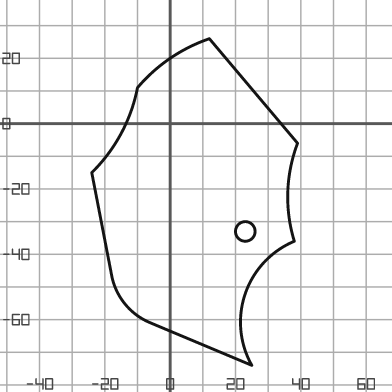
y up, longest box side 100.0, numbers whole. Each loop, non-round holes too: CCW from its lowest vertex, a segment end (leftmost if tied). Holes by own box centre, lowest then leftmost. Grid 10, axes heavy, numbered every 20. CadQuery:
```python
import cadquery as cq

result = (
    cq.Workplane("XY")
    .moveTo(25.0, -74.0)
    .threePointArc((23.0, -52.0), (38.0, -36.0))
    .threePointArc((36.0, -21.0), (39.0, -6.0))
    .lineTo(12.0, 26.0)
    .threePointArc((0.0, 20.0), (-10.0, 11.0))
    .threePointArc((-15.0, -3.0), (-24.0, -15.0))
    .lineTo(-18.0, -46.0)
    .threePointArc((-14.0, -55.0), (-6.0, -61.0))
    .close()
    .moveTo(23.0, -33.0)
    .circle(3.0)
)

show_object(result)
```